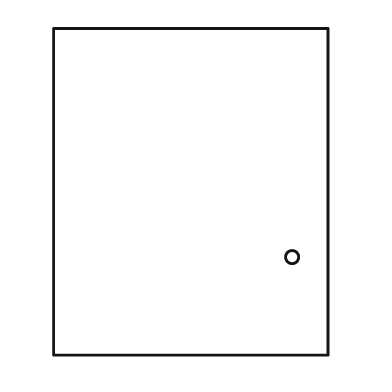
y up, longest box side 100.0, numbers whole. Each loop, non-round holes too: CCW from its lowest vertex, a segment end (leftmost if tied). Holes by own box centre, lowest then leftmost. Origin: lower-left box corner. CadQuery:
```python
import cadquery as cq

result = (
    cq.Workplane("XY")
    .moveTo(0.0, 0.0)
    .lineTo(84.0, 0.0)
    .lineTo(84.0, 100.0)
    .lineTo(0.0, 100.0)
    .close()
    .moveTo(73.0, 30.0)
    .circle(2.0)
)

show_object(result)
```